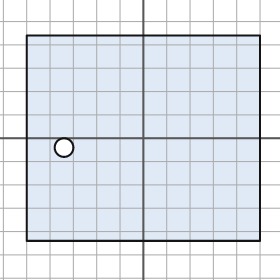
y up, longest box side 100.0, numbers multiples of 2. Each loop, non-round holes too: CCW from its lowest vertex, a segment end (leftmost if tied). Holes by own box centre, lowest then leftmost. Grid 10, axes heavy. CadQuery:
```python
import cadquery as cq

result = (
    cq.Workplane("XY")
    .moveTo(-50.0, -44.0)
    .lineTo(50.0, -44.0)
    .lineTo(50.0, 44.0)
    .lineTo(-50.0, 44.0)
    .close()
    .moveTo(-34.0, -4.0)
    .circle(4.0)
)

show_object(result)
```